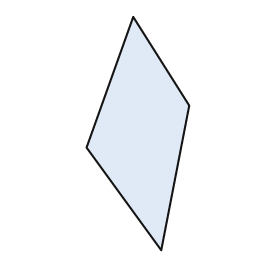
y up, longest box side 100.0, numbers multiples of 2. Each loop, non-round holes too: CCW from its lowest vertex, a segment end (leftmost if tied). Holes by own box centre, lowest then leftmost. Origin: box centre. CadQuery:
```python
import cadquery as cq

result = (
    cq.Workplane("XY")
    .moveTo(10.0, -50.0)
    .lineTo(22.0, 12.0)
    .lineTo(-2.0, 50.0)
    .lineTo(-22.0, -6.0)
    .close()
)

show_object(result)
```